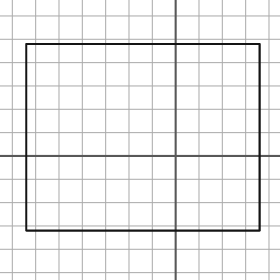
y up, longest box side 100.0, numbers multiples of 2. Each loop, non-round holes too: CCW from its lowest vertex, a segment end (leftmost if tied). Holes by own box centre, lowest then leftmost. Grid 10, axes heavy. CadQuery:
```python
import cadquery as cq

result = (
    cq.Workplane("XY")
    .moveTo(-64.0, -32.0)
    .lineTo(36.0, -32.0)
    .lineTo(36.0, 48.0)
    .lineTo(-64.0, 48.0)
    .close()
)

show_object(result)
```